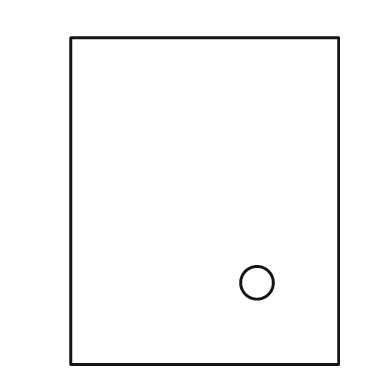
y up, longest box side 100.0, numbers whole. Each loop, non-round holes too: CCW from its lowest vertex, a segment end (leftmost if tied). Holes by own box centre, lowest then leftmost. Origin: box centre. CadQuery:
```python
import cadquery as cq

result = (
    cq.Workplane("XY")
    .moveTo(-41.0, -50.0)
    .lineTo(41.0, -50.0)
    .lineTo(41.0, 50.0)
    .lineTo(-41.0, 50.0)
    .close()
    .moveTo(16.0, -25.0)
    .circle(5.0)
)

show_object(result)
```